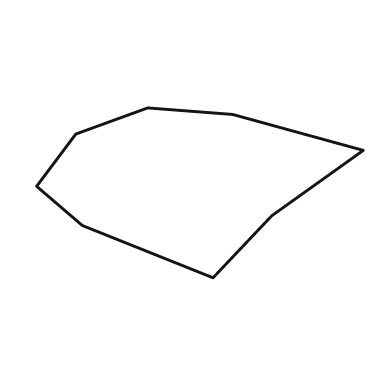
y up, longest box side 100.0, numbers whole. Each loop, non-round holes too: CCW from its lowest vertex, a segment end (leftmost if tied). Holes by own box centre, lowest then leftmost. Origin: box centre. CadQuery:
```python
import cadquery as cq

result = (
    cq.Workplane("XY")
    .moveTo(4.0, -26.0)
    .lineTo(22.0, -7.0)
    .lineTo(50.0, 13.0)
    .lineTo(10.0, 24.0)
    .lineTo(-16.0, 26.0)
    .lineTo(-38.0, 18.0)
    .lineTo(-50.0, 2.0)
    .lineTo(-36.0, -10.0)
    .close()
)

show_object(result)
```